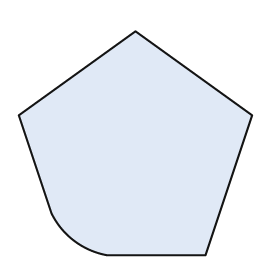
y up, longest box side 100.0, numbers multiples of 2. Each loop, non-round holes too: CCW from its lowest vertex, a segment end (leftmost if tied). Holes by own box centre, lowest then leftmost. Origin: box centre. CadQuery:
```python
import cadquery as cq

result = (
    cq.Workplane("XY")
    .moveTo(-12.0, -48.0)
    .lineTo(30.0, -48.0)
    .lineTo(50.0, 12.0)
    .lineTo(0.0, 48.0)
    .lineTo(-50.0, 12.0)
    .lineTo(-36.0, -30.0)
    .threePointArc((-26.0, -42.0), (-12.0, -48.0))
    .close()
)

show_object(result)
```